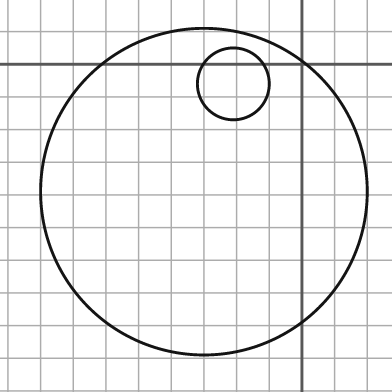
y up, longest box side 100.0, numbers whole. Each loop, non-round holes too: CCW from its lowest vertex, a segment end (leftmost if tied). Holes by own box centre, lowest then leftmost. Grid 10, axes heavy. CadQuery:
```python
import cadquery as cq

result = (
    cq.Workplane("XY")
    .moveTo(-30.0, -39.0)
    .circle(50.0)
    .moveTo(-21.0, -6.0)
    .circle(11.0)
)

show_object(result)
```